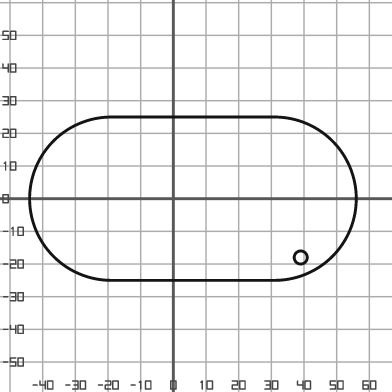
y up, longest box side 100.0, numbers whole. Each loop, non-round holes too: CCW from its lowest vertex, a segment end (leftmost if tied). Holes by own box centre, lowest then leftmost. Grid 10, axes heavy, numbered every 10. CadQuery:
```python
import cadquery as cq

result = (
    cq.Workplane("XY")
    .moveTo(-19.0, -25.0)
    .lineTo(31.0, -25.0)
    .threePointArc((56.0, 0.0), (31.0, 25.0))
    .lineTo(-19.0, 25.0)
    .threePointArc((-44.0, 0.0), (-19.0, -25.0))
    .close()
    .moveTo(39.0, -18.0)
    .circle(2.0)
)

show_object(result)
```